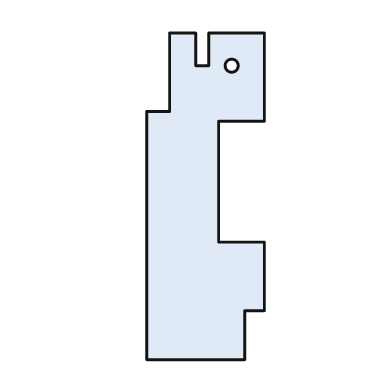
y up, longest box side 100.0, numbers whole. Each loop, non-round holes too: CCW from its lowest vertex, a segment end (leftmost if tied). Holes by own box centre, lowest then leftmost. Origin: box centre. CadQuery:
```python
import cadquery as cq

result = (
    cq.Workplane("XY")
    .moveTo(-18.0, -50.0)
    .lineTo(12.0, -50.0)
    .lineTo(12.0, -35.0)
    .lineTo(18.0, -35.0)
    .lineTo(18.0, -14.0)
    .lineTo(4.0, -14.0)
    .lineTo(4.0, 23.0)
    .lineTo(18.0, 23.0)
    .lineTo(18.0, 50.0)
    .lineTo(1.0, 50.0)
    .lineTo(1.0, 40.0)
    .lineTo(-3.0, 40.0)
    .lineTo(-3.0, 50.0)
    .lineTo(-11.0, 50.0)
    .lineTo(-11.0, 26.0)
    .lineTo(-18.0, 26.0)
    .close()
    .moveTo(8.0, 40.0)
    .circle(2.0)
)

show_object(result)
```